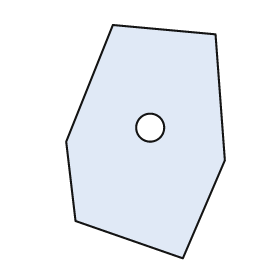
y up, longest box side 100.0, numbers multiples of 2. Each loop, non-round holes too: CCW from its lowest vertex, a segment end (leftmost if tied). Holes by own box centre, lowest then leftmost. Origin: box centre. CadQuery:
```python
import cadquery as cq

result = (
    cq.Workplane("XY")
    .moveTo(16.0, -50.0)
    .lineTo(34.0, -8.0)
    .lineTo(30.0, 46.0)
    .lineTo(-14.0, 50.0)
    .lineTo(-34.0, 0.0)
    .lineTo(-30.0, -34.0)
    .close()
    .moveTo(2.0, 6.0)
    .circle(6.0)
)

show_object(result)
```